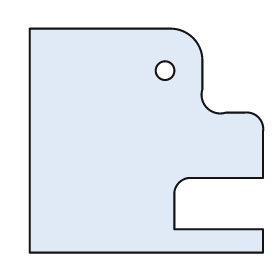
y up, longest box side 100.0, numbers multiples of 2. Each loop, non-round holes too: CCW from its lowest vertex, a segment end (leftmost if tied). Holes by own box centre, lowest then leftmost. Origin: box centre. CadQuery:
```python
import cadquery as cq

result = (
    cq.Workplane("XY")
    .moveTo(-50.0, -48.0)
    .lineTo(50.0, -48.0)
    .lineTo(50.0, -38.0)
    .lineTo(12.0, -38.0)
    .lineTo(12.0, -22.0)
    .threePointArc((14.0, -18.0), (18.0, -16.0))
    .lineTo(50.0, -16.0)
    .lineTo(50.0, 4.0)
    .threePointArc((48.0, 10.0), (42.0, 12.0))
    .lineTo(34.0, 12.0)
    .threePointArc((26.0, 14.0), (24.0, 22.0))
    .lineTo(24.0, 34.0)
    .threePointArc((20.0, 44.0), (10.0, 48.0))
    .lineTo(-50.0, 48.0)
    .close()
    .moveTo(8.0, 30.0)
    .circle(4.0)
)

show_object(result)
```